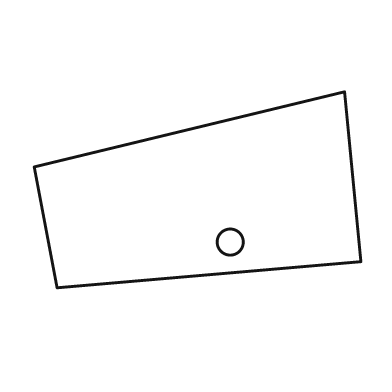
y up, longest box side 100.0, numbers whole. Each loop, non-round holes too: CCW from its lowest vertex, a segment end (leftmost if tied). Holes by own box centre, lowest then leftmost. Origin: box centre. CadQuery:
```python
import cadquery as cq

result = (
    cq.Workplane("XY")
    .moveTo(-43.0, -30.0)
    .lineTo(50.0, -22.0)
    .lineTo(45.0, 30.0)
    .lineTo(-50.0, 7.0)
    .close()
    .moveTo(10.0, -16.0)
    .circle(4.0)
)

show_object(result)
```